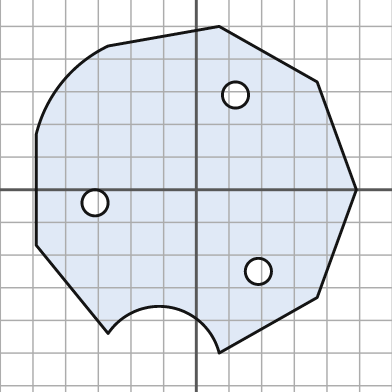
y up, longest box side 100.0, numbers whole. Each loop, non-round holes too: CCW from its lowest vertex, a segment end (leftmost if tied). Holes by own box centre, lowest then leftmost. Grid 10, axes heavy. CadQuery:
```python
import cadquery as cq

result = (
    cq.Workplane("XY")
    .moveTo(7.0, -50.0)
    .lineTo(37.0, -33.0)
    .lineTo(49.0, 0.0)
    .lineTo(37.0, 33.0)
    .lineTo(7.0, 50.0)
    .lineTo(-27.0, 44.0)
    .threePointArc((-41.0, 33.0), (-49.0, 17.0))
    .lineTo(-49.0, -17.0)
    .lineTo(-27.0, -44.0)
    .threePointArc((-8.0, -36.0), (7.0, -50.0))
    .close()
    .moveTo(19.0, -25.0)
    .circle(4.0)
    .moveTo(-31.0, -4.0)
    .circle(4.0)
    .moveTo(12.0, 29.0)
    .circle(4.0)
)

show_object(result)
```